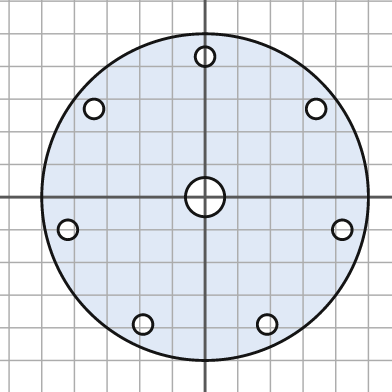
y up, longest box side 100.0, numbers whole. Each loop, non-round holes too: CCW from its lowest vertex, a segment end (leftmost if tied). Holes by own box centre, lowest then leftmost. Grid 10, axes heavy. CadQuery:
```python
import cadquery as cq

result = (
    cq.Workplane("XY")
    .moveTo(0.0, 0.0)
    .circle(50.0)
    .moveTo(-19.0, -39.0)
    .circle(3.0)
    .moveTo(19.0, -39.0)
    .circle(3.0)
    .moveTo(-42.0, -10.0)
    .circle(3.0)
    .moveTo(42.0, -10.0)
    .circle(3.0)
    .moveTo(0.0, 0.0)
    .circle(6.0)
    .moveTo(-34.0, 27.0)
    .circle(3.0)
    .moveTo(34.0, 27.0)
    .circle(3.0)
    .moveTo(0.0, 43.0)
    .circle(3.0)
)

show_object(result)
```